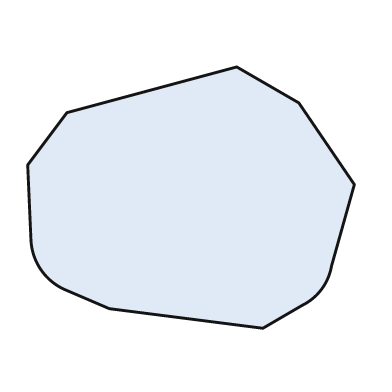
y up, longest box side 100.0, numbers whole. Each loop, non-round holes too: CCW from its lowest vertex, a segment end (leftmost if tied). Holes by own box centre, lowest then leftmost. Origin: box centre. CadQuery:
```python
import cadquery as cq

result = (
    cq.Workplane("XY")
    .moveTo(22.0, -40.0)
    .lineTo(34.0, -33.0)
    .threePointArc((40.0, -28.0), (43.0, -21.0))
    .lineTo(50.0, 4.0)
    .lineTo(33.0, 29.0)
    .lineTo(14.0, 40.0)
    .lineTo(-38.0, 26.0)
    .lineTo(-50.0, 10.0)
    .lineTo(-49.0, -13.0)
    .threePointArc((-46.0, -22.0), (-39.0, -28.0))
    .lineTo(-25.0, -34.0)
    .close()
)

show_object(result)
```